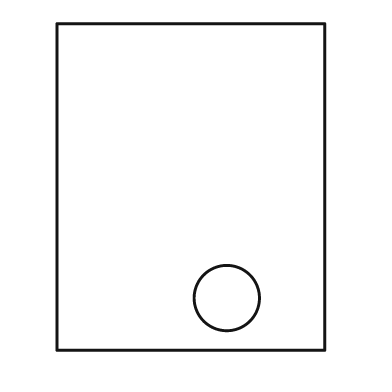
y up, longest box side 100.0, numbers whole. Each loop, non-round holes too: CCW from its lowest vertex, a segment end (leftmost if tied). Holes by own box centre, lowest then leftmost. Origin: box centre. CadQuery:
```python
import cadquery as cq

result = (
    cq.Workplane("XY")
    .moveTo(-41.0, -50.0)
    .lineTo(41.0, -50.0)
    .lineTo(41.0, 50.0)
    .lineTo(-41.0, 50.0)
    .close()
    .moveTo(11.0, -34.0)
    .circle(10.0)
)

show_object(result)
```